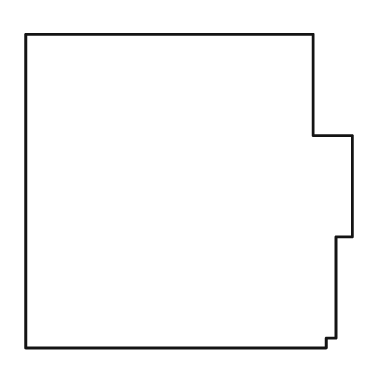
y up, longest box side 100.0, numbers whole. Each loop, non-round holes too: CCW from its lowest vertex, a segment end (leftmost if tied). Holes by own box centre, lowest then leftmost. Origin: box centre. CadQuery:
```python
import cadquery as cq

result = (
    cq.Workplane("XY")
    .moveTo(-50.0, -48.0)
    .lineTo(42.0, -48.0)
    .lineTo(42.0, -45.0)
    .lineTo(45.0, -45.0)
    .lineTo(45.0, -14.0)
    .lineTo(50.0, -14.0)
    .lineTo(50.0, 17.0)
    .lineTo(38.0, 17.0)
    .lineTo(38.0, 48.0)
    .lineTo(-50.0, 48.0)
    .close()
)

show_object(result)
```